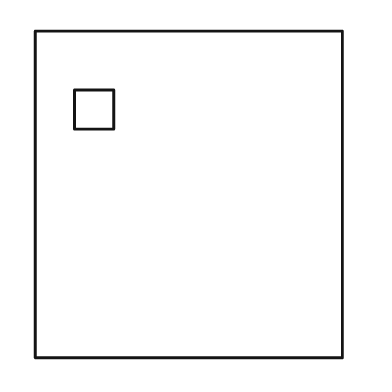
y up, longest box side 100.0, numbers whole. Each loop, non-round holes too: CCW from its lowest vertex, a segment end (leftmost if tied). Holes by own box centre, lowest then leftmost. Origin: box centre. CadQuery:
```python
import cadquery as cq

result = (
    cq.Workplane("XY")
    .moveTo(-47.0, -50.0)
    .lineTo(47.0, -50.0)
    .lineTo(47.0, 50.0)
    .lineTo(-47.0, 50.0)
    .close()
    .moveTo(-35.0, 20.0)
    .lineTo(-23.0, 20.0)
    .lineTo(-23.0, 32.0)
    .lineTo(-35.0, 32.0)
    .close()
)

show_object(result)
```